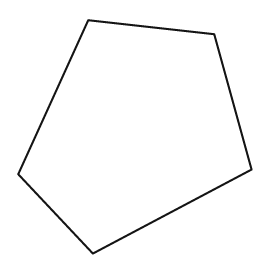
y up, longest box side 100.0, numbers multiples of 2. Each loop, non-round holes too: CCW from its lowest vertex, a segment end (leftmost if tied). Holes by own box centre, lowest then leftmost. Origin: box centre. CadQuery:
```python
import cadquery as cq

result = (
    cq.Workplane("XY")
    .moveTo(-18.0, -50.0)
    .lineTo(50.0, -14.0)
    .lineTo(34.0, 44.0)
    .lineTo(-20.0, 50.0)
    .lineTo(-50.0, -16.0)
    .close()
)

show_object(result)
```